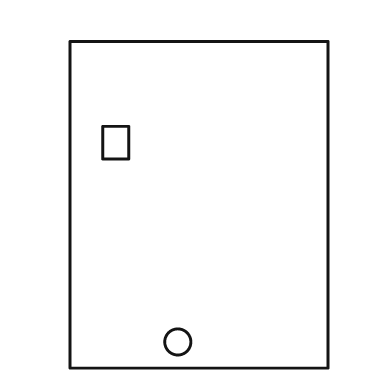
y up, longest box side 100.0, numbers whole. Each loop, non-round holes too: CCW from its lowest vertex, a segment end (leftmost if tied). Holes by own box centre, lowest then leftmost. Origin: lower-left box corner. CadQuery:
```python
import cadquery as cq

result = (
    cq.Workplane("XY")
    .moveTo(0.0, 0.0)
    .lineTo(79.0, 0.0)
    .lineTo(79.0, 100.0)
    .lineTo(0.0, 100.0)
    .close()
    .moveTo(33.0, 8.0)
    .circle(4.0)
    .moveTo(10.0, 64.0)
    .lineTo(18.0, 64.0)
    .lineTo(18.0, 74.0)
    .lineTo(10.0, 74.0)
    .close()
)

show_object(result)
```